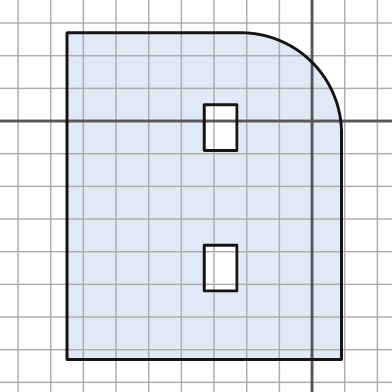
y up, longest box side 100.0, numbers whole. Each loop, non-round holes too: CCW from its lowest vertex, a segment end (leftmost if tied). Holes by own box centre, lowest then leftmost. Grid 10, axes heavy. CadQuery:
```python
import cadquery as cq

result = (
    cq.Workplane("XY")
    .moveTo(-75.0, -73.0)
    .lineTo(9.0, -73.0)
    .lineTo(9.0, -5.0)
    .threePointArc((0.0, 18.0), (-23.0, 27.0))
    .lineTo(-75.0, 27.0)
    .close()
    .moveTo(-33.0, -52.0)
    .lineTo(-23.0, -52.0)
    .lineTo(-23.0, -38.0)
    .lineTo(-33.0, -38.0)
    .close()
    .moveTo(-33.0, -9.0)
    .lineTo(-23.0, -9.0)
    .lineTo(-23.0, 5.0)
    .lineTo(-33.0, 5.0)
    .close()
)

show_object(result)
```